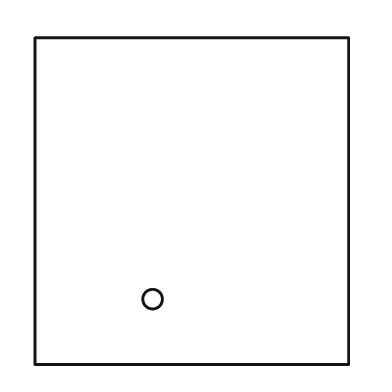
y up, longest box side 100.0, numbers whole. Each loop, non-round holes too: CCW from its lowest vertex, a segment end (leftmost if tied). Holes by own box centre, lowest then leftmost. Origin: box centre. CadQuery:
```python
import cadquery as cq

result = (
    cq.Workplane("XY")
    .moveTo(-48.0, -50.0)
    .lineTo(48.0, -50.0)
    .lineTo(48.0, 50.0)
    .lineTo(-48.0, 50.0)
    .close()
    .moveTo(-12.0, -30.0)
    .circle(3.0)
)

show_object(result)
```